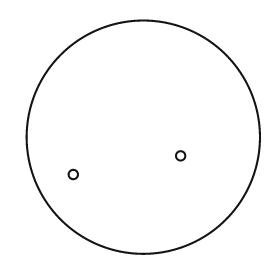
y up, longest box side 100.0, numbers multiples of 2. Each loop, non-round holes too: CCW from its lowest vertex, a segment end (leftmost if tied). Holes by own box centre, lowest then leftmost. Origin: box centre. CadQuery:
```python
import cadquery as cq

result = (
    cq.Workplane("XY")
    .moveTo(0.0, 0.0)
    .circle(50.0)
    .moveTo(-30.0, -16.0)
    .circle(2.0)
    .moveTo(16.0, -8.0)
    .circle(2.0)
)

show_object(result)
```